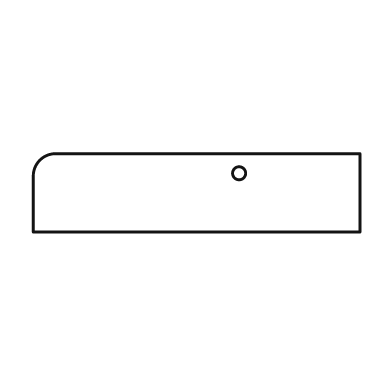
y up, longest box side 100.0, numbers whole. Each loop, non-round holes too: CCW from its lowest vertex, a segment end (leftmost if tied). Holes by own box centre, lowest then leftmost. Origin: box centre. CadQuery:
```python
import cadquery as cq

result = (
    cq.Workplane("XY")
    .moveTo(-50.0, -12.0)
    .lineTo(50.0, -12.0)
    .lineTo(50.0, 12.0)
    .lineTo(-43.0, 12.0)
    .threePointArc((-48.0, 10.0), (-50.0, 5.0))
    .close()
    .moveTo(13.0, 6.0)
    .circle(2.0)
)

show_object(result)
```